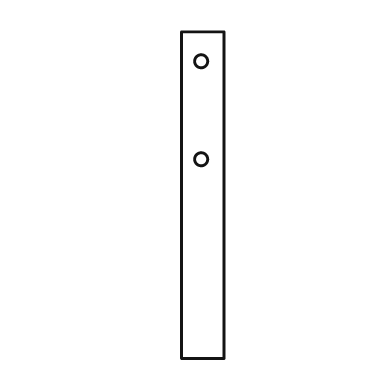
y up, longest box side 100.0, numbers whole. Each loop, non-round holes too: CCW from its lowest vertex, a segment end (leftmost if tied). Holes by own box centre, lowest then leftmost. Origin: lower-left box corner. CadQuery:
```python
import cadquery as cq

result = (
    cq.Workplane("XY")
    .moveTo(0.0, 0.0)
    .lineTo(13.0, 0.0)
    .lineTo(13.0, 100.0)
    .lineTo(0.0, 100.0)
    .close()
    .moveTo(6.0, 61.0)
    .circle(2.0)
    .moveTo(6.0, 91.0)
    .circle(2.0)
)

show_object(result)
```